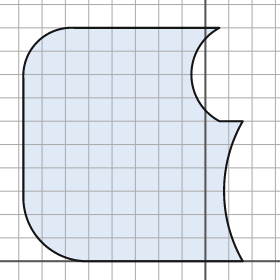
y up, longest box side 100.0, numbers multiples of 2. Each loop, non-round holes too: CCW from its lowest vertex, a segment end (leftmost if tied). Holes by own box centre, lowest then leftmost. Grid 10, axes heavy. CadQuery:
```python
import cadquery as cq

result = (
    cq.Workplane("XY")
    .moveTo(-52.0, 0.0)
    .lineTo(16.0, 0.0)
    .threePointArc((8.0, 30.0), (16.0, 60.0))
    .lineTo(6.0, 60.0)
    .threePointArc((-6.0, 80.0), (6.0, 100.0))
    .lineTo(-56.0, 100.0)
    .threePointArc((-72.0, 94.0), (-78.0, 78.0))
    .lineTo(-78.0, 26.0)
    .threePointArc((-70.0, 8.0), (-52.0, 0.0))
    .close()
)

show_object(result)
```